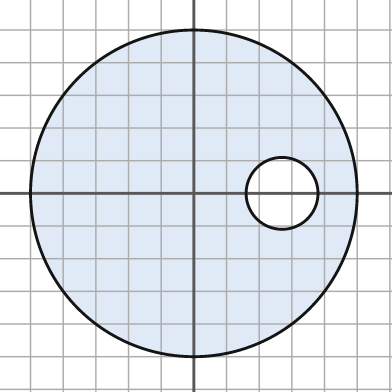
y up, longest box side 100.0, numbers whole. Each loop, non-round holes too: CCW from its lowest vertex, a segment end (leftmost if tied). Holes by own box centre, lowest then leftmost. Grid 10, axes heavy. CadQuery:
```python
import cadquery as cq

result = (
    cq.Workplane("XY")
    .moveTo(0.0, 0.0)
    .circle(50.0)
    .moveTo(27.0, 0.0)
    .circle(11.0)
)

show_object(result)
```